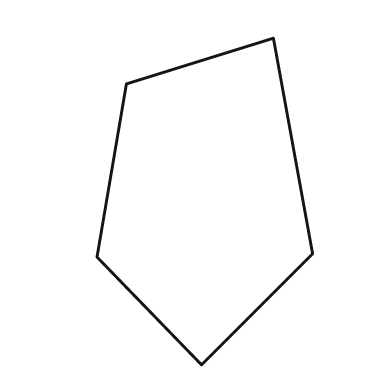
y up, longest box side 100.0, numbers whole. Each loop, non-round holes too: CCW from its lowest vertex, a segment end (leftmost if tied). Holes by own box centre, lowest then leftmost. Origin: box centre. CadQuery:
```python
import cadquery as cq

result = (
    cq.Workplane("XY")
    .moveTo(-1.0, -50.0)
    .lineTo(33.0, -16.0)
    .lineTo(21.0, 50.0)
    .lineTo(-24.0, 36.0)
    .lineTo(-33.0, -17.0)
    .close()
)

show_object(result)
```